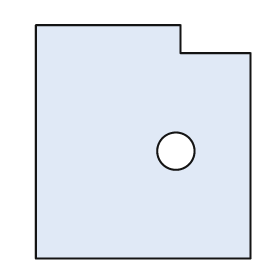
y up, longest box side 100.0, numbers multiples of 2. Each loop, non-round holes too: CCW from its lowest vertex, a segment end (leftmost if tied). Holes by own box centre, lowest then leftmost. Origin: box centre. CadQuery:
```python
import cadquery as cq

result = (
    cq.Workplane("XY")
    .moveTo(-46.0, -50.0)
    .lineTo(46.0, -50.0)
    .lineTo(46.0, 38.0)
    .lineTo(16.0, 38.0)
    .lineTo(16.0, 50.0)
    .lineTo(-46.0, 50.0)
    .close()
    .moveTo(14.0, -4.0)
    .circle(8.0)
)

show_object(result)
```